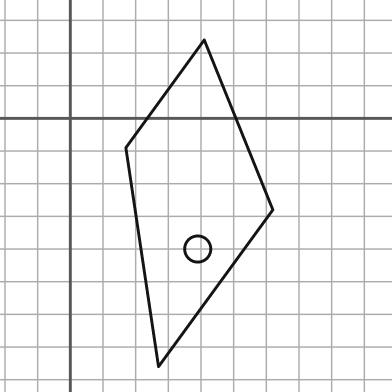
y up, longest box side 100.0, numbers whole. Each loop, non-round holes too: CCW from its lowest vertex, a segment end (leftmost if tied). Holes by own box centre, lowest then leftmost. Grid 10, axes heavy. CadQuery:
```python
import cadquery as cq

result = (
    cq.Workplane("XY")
    .moveTo(27.0, -76.0)
    .lineTo(62.0, -28.0)
    .lineTo(41.0, 24.0)
    .lineTo(17.0, -9.0)
    .close()
    .moveTo(39.0, -40.0)
    .circle(4.0)
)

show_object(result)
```